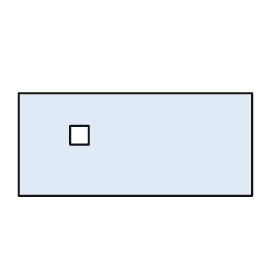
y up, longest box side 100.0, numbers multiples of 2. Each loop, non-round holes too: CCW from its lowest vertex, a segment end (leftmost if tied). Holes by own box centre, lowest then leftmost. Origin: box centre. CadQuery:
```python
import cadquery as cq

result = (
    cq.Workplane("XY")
    .moveTo(-50.0, -22.0)
    .lineTo(50.0, -22.0)
    .lineTo(50.0, 22.0)
    .lineTo(-50.0, 22.0)
    .close()
    .moveTo(-28.0, 0.0)
    .lineTo(-20.0, 0.0)
    .lineTo(-20.0, 8.0)
    .lineTo(-28.0, 8.0)
    .close()
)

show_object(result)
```